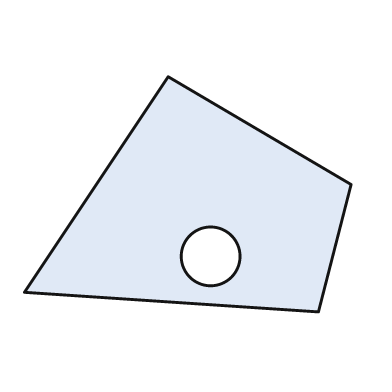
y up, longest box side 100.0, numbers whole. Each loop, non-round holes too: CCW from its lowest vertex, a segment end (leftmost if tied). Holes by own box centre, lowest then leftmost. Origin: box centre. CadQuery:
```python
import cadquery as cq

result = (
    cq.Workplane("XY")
    .moveTo(40.0, -36.0)
    .lineTo(50.0, 3.0)
    .lineTo(-6.0, 36.0)
    .lineTo(-50.0, -30.0)
    .close()
    .moveTo(7.0, -19.0)
    .circle(9.0)
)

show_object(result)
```